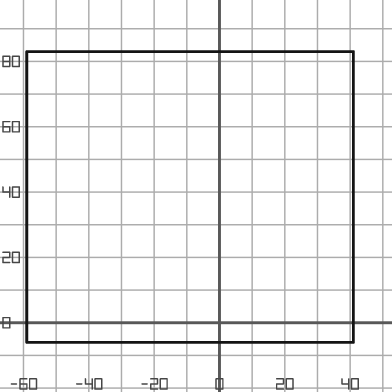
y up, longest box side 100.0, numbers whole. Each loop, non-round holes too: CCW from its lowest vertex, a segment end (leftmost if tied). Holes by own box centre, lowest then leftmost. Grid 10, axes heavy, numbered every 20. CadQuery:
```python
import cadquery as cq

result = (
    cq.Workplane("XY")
    .moveTo(-59.0, -6.0)
    .lineTo(41.0, -6.0)
    .lineTo(41.0, 83.0)
    .lineTo(-59.0, 83.0)
    .close()
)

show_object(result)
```